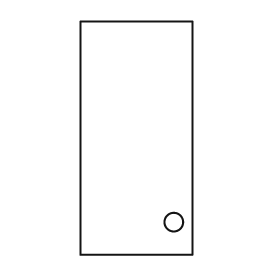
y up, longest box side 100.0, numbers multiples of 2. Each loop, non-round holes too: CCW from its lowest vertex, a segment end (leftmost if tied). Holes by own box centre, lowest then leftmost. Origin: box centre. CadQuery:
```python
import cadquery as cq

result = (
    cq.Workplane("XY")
    .moveTo(-24.0, -50.0)
    .lineTo(24.0, -50.0)
    .lineTo(24.0, 50.0)
    .lineTo(-24.0, 50.0)
    .close()
    .moveTo(16.0, -36.0)
    .circle(4.0)
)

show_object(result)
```